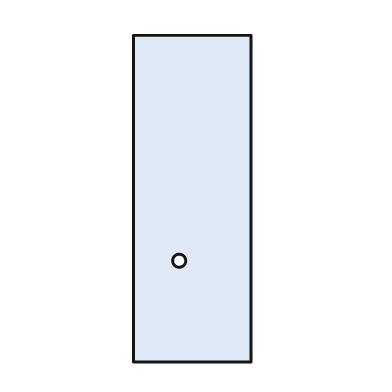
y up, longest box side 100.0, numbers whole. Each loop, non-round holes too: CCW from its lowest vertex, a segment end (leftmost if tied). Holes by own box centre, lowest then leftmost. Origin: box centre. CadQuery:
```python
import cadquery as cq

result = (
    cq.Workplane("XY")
    .moveTo(-18.0, -50.0)
    .lineTo(18.0, -50.0)
    .lineTo(18.0, 50.0)
    .lineTo(-18.0, 50.0)
    .close()
    .moveTo(-4.0, -19.0)
    .circle(2.0)
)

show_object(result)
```